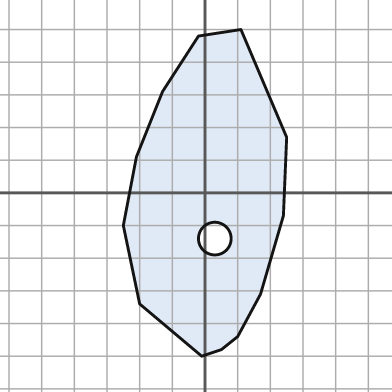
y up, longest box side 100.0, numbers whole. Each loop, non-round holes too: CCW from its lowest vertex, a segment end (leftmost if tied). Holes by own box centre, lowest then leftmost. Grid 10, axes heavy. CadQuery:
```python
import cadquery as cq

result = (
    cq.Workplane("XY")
    .moveTo(-1.0, -50.0)
    .lineTo(5.0, -48.0)
    .lineTo(10.0, -44.0)
    .lineTo(17.0, -31.0)
    .lineTo(24.0, -7.0)
    .lineTo(25.0, 17.0)
    .lineTo(11.0, 50.0)
    .lineTo(-2.0, 48.0)
    .lineTo(-13.0, 31.0)
    .lineTo(-21.0, 11.0)
    .lineTo(-25.0, -10.0)
    .lineTo(-20.0, -34.0)
    .close()
    .moveTo(3.0, -14.0)
    .circle(5.0)
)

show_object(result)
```